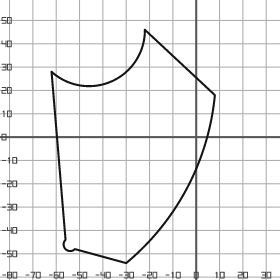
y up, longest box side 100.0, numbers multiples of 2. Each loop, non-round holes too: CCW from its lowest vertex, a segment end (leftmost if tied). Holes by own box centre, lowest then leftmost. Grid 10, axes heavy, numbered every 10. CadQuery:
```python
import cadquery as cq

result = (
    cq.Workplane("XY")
    .moveTo(-30.0, -54.0)
    .threePointArc((-4.0, -22.0), (8.0, 18.0))
    .lineTo(-22.0, 46.0)
    .threePointArc((-36.0, 24.0), (-62.0, 28.0))
    .lineTo(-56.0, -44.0)
    .threePointArc((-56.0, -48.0), (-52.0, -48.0))
    .close()
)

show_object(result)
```